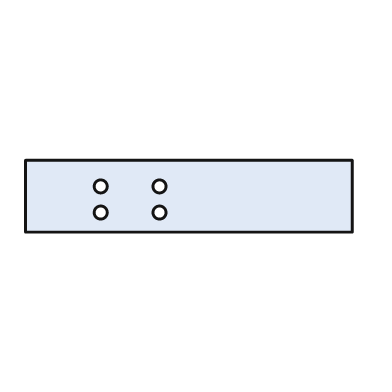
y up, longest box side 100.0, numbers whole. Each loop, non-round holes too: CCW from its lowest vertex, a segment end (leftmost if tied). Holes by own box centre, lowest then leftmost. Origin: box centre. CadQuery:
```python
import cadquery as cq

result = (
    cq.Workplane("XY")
    .moveTo(-50.0, -11.0)
    .lineTo(50.0, -11.0)
    .lineTo(50.0, 11.0)
    .lineTo(-50.0, 11.0)
    .close()
    .moveTo(-27.0, -5.0)
    .circle(2.0)
    .moveTo(-9.0, -5.0)
    .circle(2.0)
    .moveTo(-27.0, 3.0)
    .circle(2.0)
    .moveTo(-9.0, 3.0)
    .circle(2.0)
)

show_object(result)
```